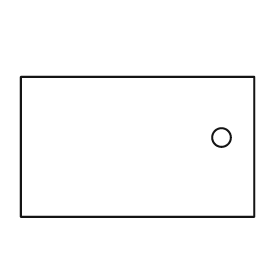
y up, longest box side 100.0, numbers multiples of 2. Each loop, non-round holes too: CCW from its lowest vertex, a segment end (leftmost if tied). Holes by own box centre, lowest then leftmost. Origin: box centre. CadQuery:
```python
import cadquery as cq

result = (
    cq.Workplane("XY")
    .moveTo(-50.0, -30.0)
    .lineTo(50.0, -30.0)
    .lineTo(50.0, 30.0)
    .lineTo(-50.0, 30.0)
    .close()
    .moveTo(36.0, 4.0)
    .circle(4.0)
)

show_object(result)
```